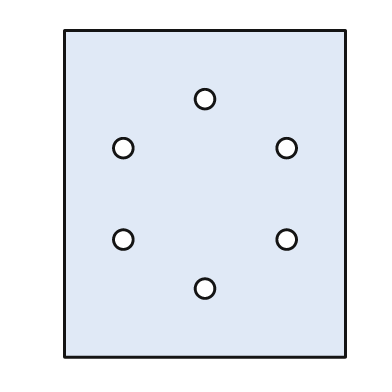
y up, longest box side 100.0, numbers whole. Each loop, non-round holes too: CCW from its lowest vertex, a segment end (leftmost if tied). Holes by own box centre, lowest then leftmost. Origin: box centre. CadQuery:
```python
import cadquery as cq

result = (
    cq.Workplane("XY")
    .moveTo(-43.0, -50.0)
    .lineTo(43.0, -50.0)
    .lineTo(43.0, 50.0)
    .lineTo(-43.0, 50.0)
    .close()
    .moveTo(0.0, -29.0)
    .circle(3.0)
    .moveTo(-25.0, -14.0)
    .circle(3.0)
    .moveTo(25.0, -14.0)
    .circle(3.0)
    .moveTo(-25.0, 14.0)
    .circle(3.0)
    .moveTo(25.0, 14.0)
    .circle(3.0)
    .moveTo(0.0, 29.0)
    .circle(3.0)
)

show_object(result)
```